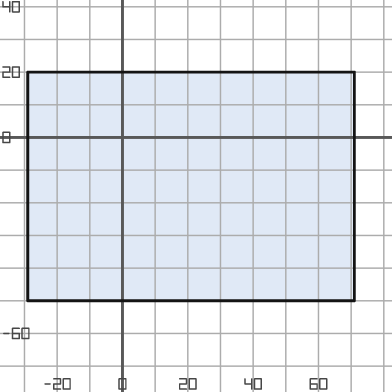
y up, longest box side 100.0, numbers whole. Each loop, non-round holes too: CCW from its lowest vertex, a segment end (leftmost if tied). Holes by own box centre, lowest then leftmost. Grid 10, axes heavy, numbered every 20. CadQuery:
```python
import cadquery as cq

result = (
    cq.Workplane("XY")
    .moveTo(-29.0, -50.0)
    .lineTo(71.0, -50.0)
    .lineTo(71.0, 20.0)
    .lineTo(-29.0, 20.0)
    .close()
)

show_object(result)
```